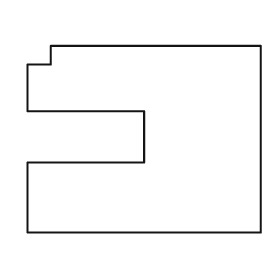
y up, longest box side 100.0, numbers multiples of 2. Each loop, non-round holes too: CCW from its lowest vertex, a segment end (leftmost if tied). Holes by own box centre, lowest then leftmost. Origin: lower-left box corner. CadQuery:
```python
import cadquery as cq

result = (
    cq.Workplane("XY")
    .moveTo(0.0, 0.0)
    .lineTo(100.0, 0.0)
    .lineTo(100.0, 80.0)
    .lineTo(10.0, 80.0)
    .lineTo(10.0, 72.0)
    .lineTo(0.0, 72.0)
    .lineTo(0.0, 52.0)
    .lineTo(50.0, 52.0)
    .lineTo(50.0, 30.0)
    .lineTo(0.0, 30.0)
    .close()
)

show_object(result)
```